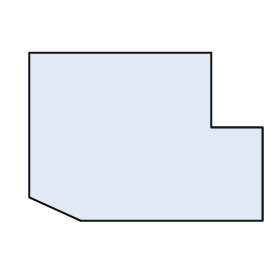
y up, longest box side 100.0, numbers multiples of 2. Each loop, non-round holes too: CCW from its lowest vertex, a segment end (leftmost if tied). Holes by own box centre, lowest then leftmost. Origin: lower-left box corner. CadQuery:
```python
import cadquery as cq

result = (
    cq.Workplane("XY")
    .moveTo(22.0, 0.0)
    .lineTo(100.0, 0.0)
    .lineTo(100.0, 40.0)
    .lineTo(78.0, 40.0)
    .lineTo(78.0, 72.0)
    .lineTo(0.0, 72.0)
    .lineTo(0.0, 10.0)
    .close()
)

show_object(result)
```